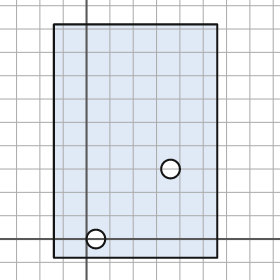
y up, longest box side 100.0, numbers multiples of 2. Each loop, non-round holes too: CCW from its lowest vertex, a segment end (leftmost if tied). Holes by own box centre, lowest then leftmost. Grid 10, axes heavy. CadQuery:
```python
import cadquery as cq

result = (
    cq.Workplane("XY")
    .moveTo(-14.0, -8.0)
    .lineTo(56.0, -8.0)
    .lineTo(56.0, 92.0)
    .lineTo(-14.0, 92.0)
    .close()
    .moveTo(4.0, 0.0)
    .circle(4.0)
    .moveTo(36.0, 30.0)
    .circle(4.0)
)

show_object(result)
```